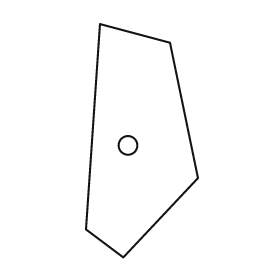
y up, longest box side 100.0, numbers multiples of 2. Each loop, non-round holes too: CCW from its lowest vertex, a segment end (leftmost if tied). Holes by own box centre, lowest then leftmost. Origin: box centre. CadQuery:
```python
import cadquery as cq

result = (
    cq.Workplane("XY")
    .moveTo(-8.0, -50.0)
    .lineTo(24.0, -16.0)
    .lineTo(12.0, 42.0)
    .lineTo(-18.0, 50.0)
    .lineTo(-24.0, -38.0)
    .close()
    .moveTo(-6.0, -2.0)
    .circle(4.0)
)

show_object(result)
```